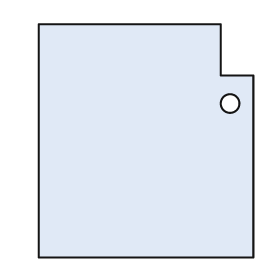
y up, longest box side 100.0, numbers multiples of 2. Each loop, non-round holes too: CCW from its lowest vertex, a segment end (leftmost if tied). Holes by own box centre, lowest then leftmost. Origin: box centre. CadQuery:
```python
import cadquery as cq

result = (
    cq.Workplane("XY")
    .moveTo(-46.0, -50.0)
    .lineTo(46.0, -50.0)
    .lineTo(46.0, 28.0)
    .lineTo(32.0, 28.0)
    .lineTo(32.0, 50.0)
    .lineTo(-46.0, 50.0)
    .close()
    .moveTo(36.0, 16.0)
    .circle(4.0)
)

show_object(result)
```